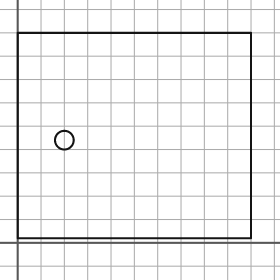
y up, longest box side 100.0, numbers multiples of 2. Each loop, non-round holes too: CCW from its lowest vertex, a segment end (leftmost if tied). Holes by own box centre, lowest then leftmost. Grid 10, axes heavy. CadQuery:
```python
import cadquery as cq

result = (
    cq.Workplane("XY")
    .moveTo(0.0, 2.0)
    .lineTo(100.0, 2.0)
    .lineTo(100.0, 90.0)
    .lineTo(0.0, 90.0)
    .close()
    .moveTo(20.0, 44.0)
    .circle(4.0)
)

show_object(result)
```